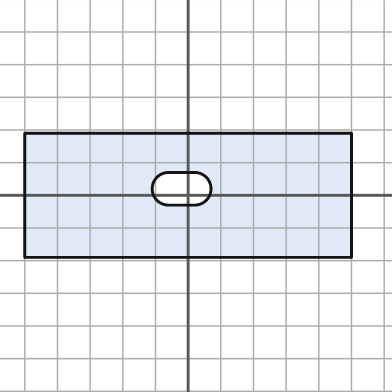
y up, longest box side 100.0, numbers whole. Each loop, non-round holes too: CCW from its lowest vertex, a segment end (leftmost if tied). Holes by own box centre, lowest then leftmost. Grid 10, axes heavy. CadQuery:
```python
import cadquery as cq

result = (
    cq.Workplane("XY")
    .moveTo(-50.0, -19.0)
    .lineTo(50.0, -19.0)
    .lineTo(50.0, 19.0)
    .lineTo(-50.0, 19.0)
    .close()
    .moveTo(-6.0, -3.0)
    .lineTo(2.0, -3.0)
    .threePointArc((7.0, 2.0), (2.0, 7.0))
    .lineTo(-6.0, 7.0)
    .threePointArc((-11.0, 2.0), (-6.0, -3.0))
    .close()
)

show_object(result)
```